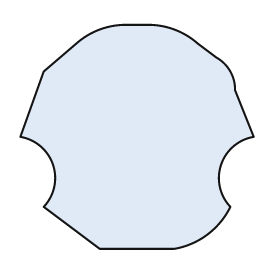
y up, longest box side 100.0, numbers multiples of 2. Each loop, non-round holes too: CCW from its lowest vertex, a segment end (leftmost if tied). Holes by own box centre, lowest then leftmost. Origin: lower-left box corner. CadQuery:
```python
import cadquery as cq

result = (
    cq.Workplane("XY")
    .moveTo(34.0, 0.0)
    .lineTo(66.0, 0.0)
    .threePointArc((80.0, 6.0), (90.0, 18.0))
    .threePointArc((86.0, 36.0), (100.0, 48.0))
    .lineTo(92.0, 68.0)
    .threePointArc((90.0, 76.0), (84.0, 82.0))
    .lineTo(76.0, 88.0)
    .threePointArc((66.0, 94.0), (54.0, 96.0))
    .lineTo(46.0, 96.0)
    .threePointArc((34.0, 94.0), (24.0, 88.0))
    .lineTo(10.0, 76.0)
    .lineTo(0.0, 48.0)
    .threePointArc((14.0, 36.0), (10.0, 18.0))
    .close()
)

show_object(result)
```